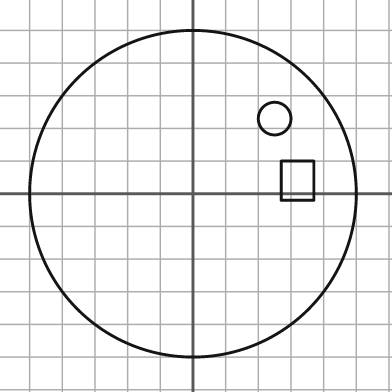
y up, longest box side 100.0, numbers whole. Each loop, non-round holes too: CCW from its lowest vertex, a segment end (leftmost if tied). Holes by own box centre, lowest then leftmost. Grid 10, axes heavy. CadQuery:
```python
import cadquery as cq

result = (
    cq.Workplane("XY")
    .moveTo(0.0, 0.0)
    .circle(50.0)
    .moveTo(27.0, -2.0)
    .lineTo(37.0, -2.0)
    .lineTo(37.0, 10.0)
    .lineTo(27.0, 10.0)
    .close()
    .moveTo(25.0, 23.0)
    .circle(5.0)
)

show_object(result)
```